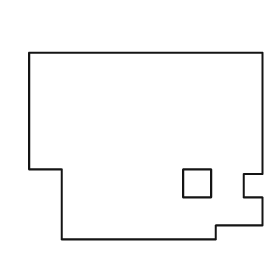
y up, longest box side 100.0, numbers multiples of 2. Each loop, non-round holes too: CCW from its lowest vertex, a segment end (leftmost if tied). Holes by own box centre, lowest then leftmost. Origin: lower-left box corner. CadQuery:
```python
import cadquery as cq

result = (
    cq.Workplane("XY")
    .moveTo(14.0, 0.0)
    .lineTo(80.0, 0.0)
    .lineTo(80.0, 6.0)
    .lineTo(100.0, 6.0)
    .lineTo(100.0, 18.0)
    .lineTo(92.0, 18.0)
    .lineTo(92.0, 28.0)
    .lineTo(100.0, 28.0)
    .lineTo(100.0, 80.0)
    .lineTo(0.0, 80.0)
    .lineTo(0.0, 30.0)
    .lineTo(14.0, 30.0)
    .close()
    .moveTo(66.0, 18.0)
    .lineTo(78.0, 18.0)
    .lineTo(78.0, 30.0)
    .lineTo(66.0, 30.0)
    .close()
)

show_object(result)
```